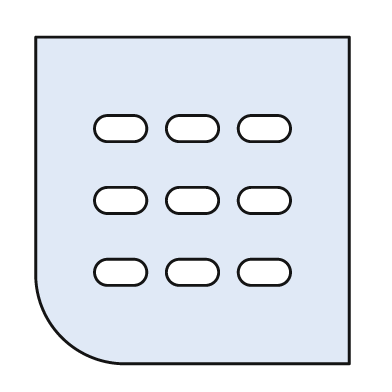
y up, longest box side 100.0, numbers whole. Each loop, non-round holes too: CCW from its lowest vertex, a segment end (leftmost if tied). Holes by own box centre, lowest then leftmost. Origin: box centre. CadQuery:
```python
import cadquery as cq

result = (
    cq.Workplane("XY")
    .moveTo(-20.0, -50.0)
    .lineTo(48.0, -50.0)
    .lineTo(48.0, 50.0)
    .lineTo(-48.0, 50.0)
    .lineTo(-48.0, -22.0)
    .threePointArc((-40.0, -42.0), (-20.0, -50.0))
    .close()
    .moveTo(-26.0, -26.0)
    .lineTo(-18.0, -26.0)
    .threePointArc((-14.0, -22.0), (-18.0, -18.0))
    .lineTo(-26.0, -18.0)
    .threePointArc((-30.0, -22.0), (-26.0, -26.0))
    .close()
    .moveTo(-4.0, -26.0)
    .lineTo(4.0, -26.0)
    .threePointArc((8.0, -22.0), (4.0, -18.0))
    .lineTo(-4.0, -18.0)
    .threePointArc((-8.0, -22.0), (-4.0, -26.0))
    .close()
    .moveTo(18.0, -26.0)
    .lineTo(26.0, -26.0)
    .threePointArc((30.0, -22.0), (26.0, -18.0))
    .lineTo(18.0, -18.0)
    .threePointArc((14.0, -22.0), (18.0, -26.0))
    .close()
    .moveTo(-26.0, -4.0)
    .lineTo(-18.0, -4.0)
    .threePointArc((-14.0, 0.0), (-18.0, 4.0))
    .lineTo(-26.0, 4.0)
    .threePointArc((-30.0, 0.0), (-26.0, -4.0))
    .close()
    .moveTo(-4.0, -4.0)
    .lineTo(4.0, -4.0)
    .threePointArc((8.0, 0.0), (4.0, 4.0))
    .lineTo(-4.0, 4.0)
    .threePointArc((-8.0, 0.0), (-4.0, -4.0))
    .close()
    .moveTo(18.0, -4.0)
    .lineTo(26.0, -4.0)
    .threePointArc((30.0, 0.0), (26.0, 4.0))
    .lineTo(18.0, 4.0)
    .threePointArc((14.0, 0.0), (18.0, -4.0))
    .close()
    .moveTo(-26.0, 18.0)
    .lineTo(-18.0, 18.0)
    .threePointArc((-14.0, 22.0), (-18.0, 26.0))
    .lineTo(-26.0, 26.0)
    .threePointArc((-30.0, 22.0), (-26.0, 18.0))
    .close()
    .moveTo(-4.0, 18.0)
    .lineTo(4.0, 18.0)
    .threePointArc((8.0, 22.0), (4.0, 26.0))
    .lineTo(-4.0, 26.0)
    .threePointArc((-8.0, 22.0), (-4.0, 18.0))
    .close()
    .moveTo(18.0, 18.0)
    .lineTo(26.0, 18.0)
    .threePointArc((30.0, 22.0), (26.0, 26.0))
    .lineTo(18.0, 26.0)
    .threePointArc((14.0, 22.0), (18.0, 18.0))
    .close()
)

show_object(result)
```